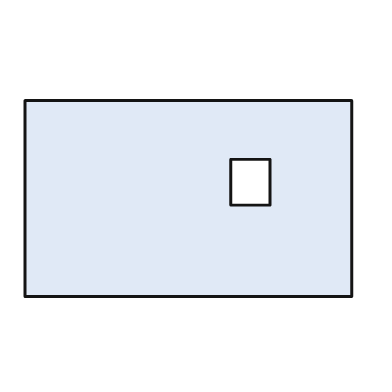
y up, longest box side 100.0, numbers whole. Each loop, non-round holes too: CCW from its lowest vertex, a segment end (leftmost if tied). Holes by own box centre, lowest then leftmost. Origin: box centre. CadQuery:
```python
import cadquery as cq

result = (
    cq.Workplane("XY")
    .moveTo(-50.0, -30.0)
    .lineTo(50.0, -30.0)
    .lineTo(50.0, 30.0)
    .lineTo(-50.0, 30.0)
    .close()
    .moveTo(13.0, -2.0)
    .lineTo(25.0, -2.0)
    .lineTo(25.0, 12.0)
    .lineTo(13.0, 12.0)
    .close()
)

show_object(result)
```